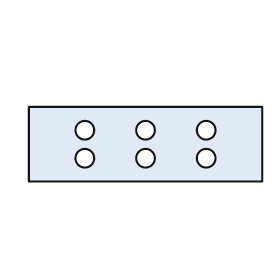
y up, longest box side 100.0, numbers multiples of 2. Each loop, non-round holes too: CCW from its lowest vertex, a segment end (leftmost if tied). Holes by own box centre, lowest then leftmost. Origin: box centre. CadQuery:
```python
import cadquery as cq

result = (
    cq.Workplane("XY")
    .moveTo(-50.0, -16.0)
    .lineTo(50.0, -16.0)
    .lineTo(50.0, 16.0)
    .lineTo(-50.0, 16.0)
    .close()
    .moveTo(-26.0, -6.0)
    .circle(4.0)
    .moveTo(0.0, -6.0)
    .circle(4.0)
    .moveTo(26.0, -6.0)
    .circle(4.0)
    .moveTo(-26.0, 6.0)
    .circle(4.0)
    .moveTo(0.0, 6.0)
    .circle(4.0)
    .moveTo(26.0, 6.0)
    .circle(4.0)
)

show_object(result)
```